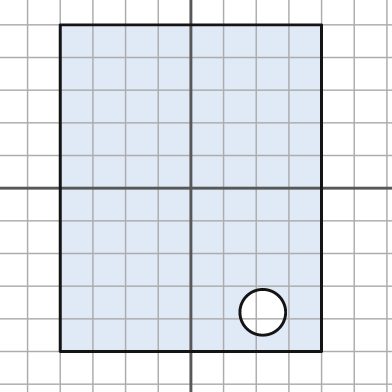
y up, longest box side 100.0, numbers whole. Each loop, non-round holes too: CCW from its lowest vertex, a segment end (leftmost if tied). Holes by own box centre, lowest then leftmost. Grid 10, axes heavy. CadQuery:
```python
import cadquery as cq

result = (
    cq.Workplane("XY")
    .moveTo(-40.0, -50.0)
    .lineTo(40.0, -50.0)
    .lineTo(40.0, 50.0)
    .lineTo(-40.0, 50.0)
    .close()
    .moveTo(22.0, -38.0)
    .circle(7.0)
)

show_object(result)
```